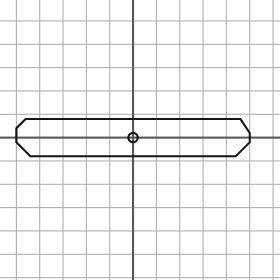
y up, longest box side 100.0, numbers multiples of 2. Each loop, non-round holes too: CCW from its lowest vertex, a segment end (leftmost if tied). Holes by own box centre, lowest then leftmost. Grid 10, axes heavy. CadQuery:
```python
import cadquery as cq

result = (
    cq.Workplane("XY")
    .moveTo(-44.0, -8.0)
    .lineTo(44.0, -8.0)
    .lineTo(50.0, -2.0)
    .lineTo(50.0, 2.0)
    .lineTo(46.0, 8.0)
    .lineTo(-46.0, 8.0)
    .lineTo(-50.0, 4.0)
    .lineTo(-50.0, -2.0)
    .close()
    .moveTo(0.0, 0.0)
    .circle(2.0)
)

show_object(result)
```